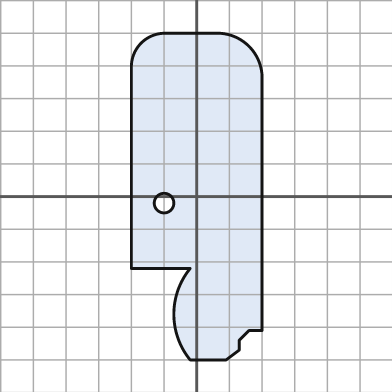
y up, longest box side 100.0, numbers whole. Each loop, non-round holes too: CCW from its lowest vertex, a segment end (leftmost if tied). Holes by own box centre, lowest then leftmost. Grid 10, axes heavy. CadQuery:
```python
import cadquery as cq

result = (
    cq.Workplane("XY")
    .moveTo(-2.0, -50.0)
    .lineTo(9.0, -50.0)
    .lineTo(13.0, -47.0)
    .lineTo(13.0, -44.0)
    .lineTo(16.0, -41.0)
    .lineTo(20.0, -41.0)
    .lineTo(20.0, 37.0)
    .threePointArc((16.0, 46.0), (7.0, 50.0))
    .lineTo(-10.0, 50.0)
    .threePointArc((-17.0, 47.0), (-20.0, 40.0))
    .lineTo(-20.0, -22.0)
    .lineTo(-2.0, -22.0)
    .threePointArc((-7.0, -36.0), (-2.0, -50.0))
    .close()
    .moveTo(-10.0, -2.0)
    .circle(3.0)
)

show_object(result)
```